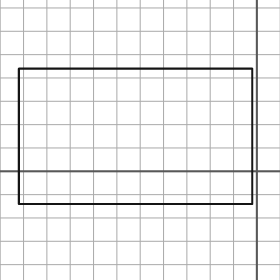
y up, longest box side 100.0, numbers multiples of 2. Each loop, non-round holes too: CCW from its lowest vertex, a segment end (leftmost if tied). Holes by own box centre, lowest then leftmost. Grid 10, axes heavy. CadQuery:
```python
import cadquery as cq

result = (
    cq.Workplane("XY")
    .moveTo(-102.0, -14.0)
    .lineTo(-2.0, -14.0)
    .lineTo(-2.0, 44.0)
    .lineTo(-102.0, 44.0)
    .close()
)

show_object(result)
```